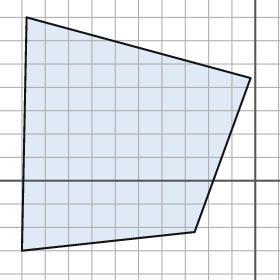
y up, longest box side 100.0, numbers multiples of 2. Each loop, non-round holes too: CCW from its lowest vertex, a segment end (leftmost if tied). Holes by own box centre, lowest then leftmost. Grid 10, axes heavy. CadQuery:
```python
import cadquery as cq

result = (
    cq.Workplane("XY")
    .moveTo(-100.0, -30.0)
    .lineTo(-26.0, -22.0)
    .lineTo(-2.0, 44.0)
    .lineTo(-98.0, 70.0)
    .close()
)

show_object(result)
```